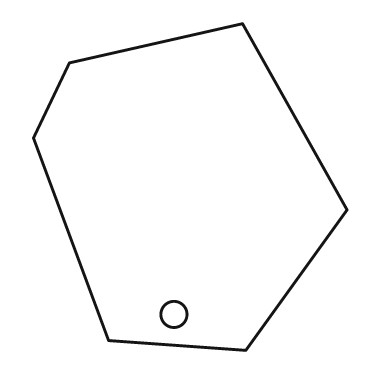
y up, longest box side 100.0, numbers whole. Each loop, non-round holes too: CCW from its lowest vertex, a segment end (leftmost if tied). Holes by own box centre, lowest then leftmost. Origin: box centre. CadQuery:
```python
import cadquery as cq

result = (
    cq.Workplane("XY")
    .moveTo(17.0, -50.0)
    .lineTo(48.0, -7.0)
    .lineTo(16.0, 50.0)
    .lineTo(-37.0, 38.0)
    .lineTo(-48.0, 15.0)
    .lineTo(-25.0, -47.0)
    .close()
    .moveTo(-5.0, -39.0)
    .circle(4.0)
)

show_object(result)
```